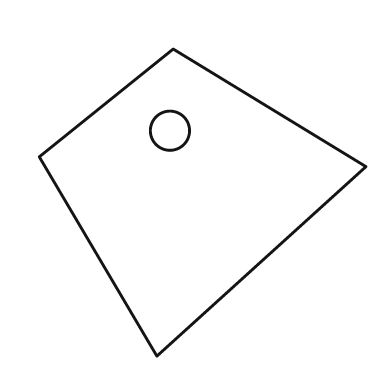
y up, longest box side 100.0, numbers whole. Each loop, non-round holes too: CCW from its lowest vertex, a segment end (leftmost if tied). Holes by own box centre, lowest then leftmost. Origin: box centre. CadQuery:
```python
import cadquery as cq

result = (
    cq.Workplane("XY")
    .moveTo(-14.0, -47.0)
    .lineTo(50.0, 11.0)
    .lineTo(-9.0, 47.0)
    .lineTo(-50.0, 14.0)
    .close()
    .moveTo(-10.0, 22.0)
    .circle(6.0)
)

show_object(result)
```